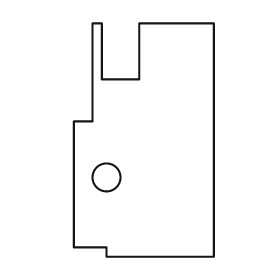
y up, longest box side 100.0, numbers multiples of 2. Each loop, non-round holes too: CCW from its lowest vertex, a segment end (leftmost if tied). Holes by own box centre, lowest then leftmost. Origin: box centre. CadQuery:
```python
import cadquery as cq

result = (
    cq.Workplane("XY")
    .moveTo(-16.0, -50.0)
    .lineTo(30.0, -50.0)
    .lineTo(30.0, 50.0)
    .lineTo(-2.0, 50.0)
    .lineTo(-2.0, 26.0)
    .lineTo(-18.0, 26.0)
    .lineTo(-18.0, 50.0)
    .lineTo(-22.0, 50.0)
    .lineTo(-22.0, 8.0)
    .lineTo(-30.0, 8.0)
    .lineTo(-30.0, -46.0)
    .lineTo(-16.0, -46.0)
    .close()
    .moveTo(-16.0, -16.0)
    .circle(6.0)
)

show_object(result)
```